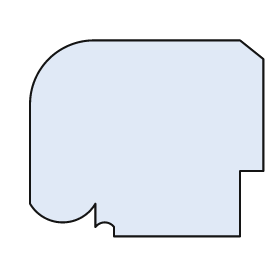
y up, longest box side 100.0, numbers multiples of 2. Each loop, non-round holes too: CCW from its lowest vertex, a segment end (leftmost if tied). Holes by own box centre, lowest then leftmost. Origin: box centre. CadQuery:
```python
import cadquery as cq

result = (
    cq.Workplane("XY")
    .moveTo(-14.0, -42.0)
    .lineTo(40.0, -42.0)
    .lineTo(40.0, -14.0)
    .lineTo(50.0, -14.0)
    .lineTo(50.0, 34.0)
    .lineTo(40.0, 42.0)
    .lineTo(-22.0, 42.0)
    .threePointArc((-42.0, 34.0), (-50.0, 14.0))
    .lineTo(-50.0, -28.0)
    .threePointArc((-36.0, -36.0), (-22.0, -28.0))
    .lineTo(-22.0, -38.0)
    .threePointArc((-18.0, -36.0), (-14.0, -38.0))
    .close()
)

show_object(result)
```